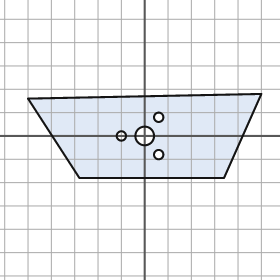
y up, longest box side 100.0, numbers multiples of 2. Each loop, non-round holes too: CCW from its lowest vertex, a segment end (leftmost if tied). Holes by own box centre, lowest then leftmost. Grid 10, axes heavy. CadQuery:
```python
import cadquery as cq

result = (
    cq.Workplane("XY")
    .moveTo(-28.0, -18.0)
    .lineTo(34.0, -18.0)
    .lineTo(50.0, 18.0)
    .lineTo(-50.0, 16.0)
    .close()
    .moveTo(6.0, -8.0)
    .circle(2.0)
    .moveTo(-10.0, 0.0)
    .circle(2.0)
    .moveTo(0.0, 0.0)
    .circle(4.0)
    .moveTo(6.0, 8.0)
    .circle(2.0)
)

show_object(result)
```